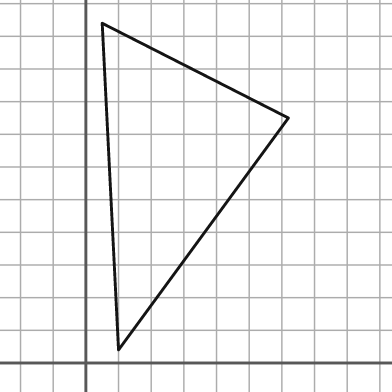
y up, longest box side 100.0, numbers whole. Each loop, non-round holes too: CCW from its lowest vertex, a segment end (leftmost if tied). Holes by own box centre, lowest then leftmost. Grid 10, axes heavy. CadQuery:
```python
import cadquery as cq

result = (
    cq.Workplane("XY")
    .moveTo(10.0, 4.0)
    .lineTo(62.0, 75.0)
    .lineTo(5.0, 104.0)
    .close()
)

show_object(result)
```